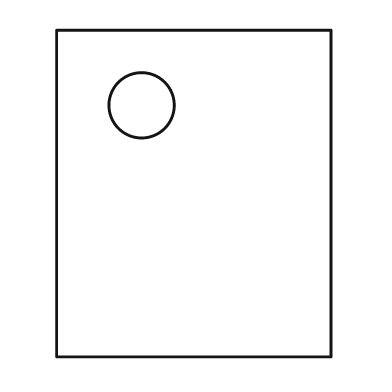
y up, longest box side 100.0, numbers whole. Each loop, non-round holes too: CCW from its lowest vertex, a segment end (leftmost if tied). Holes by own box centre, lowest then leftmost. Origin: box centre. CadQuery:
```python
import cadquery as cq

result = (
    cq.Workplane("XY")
    .moveTo(-42.0, -50.0)
    .lineTo(42.0, -50.0)
    .lineTo(42.0, 50.0)
    .lineTo(-42.0, 50.0)
    .close()
    .moveTo(-16.0, 27.0)
    .circle(10.0)
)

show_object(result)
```